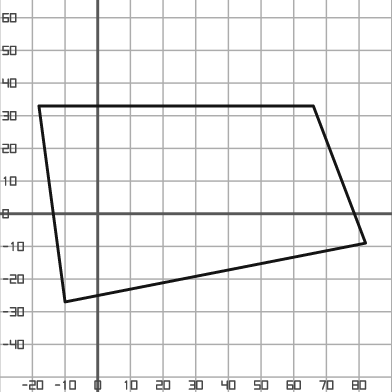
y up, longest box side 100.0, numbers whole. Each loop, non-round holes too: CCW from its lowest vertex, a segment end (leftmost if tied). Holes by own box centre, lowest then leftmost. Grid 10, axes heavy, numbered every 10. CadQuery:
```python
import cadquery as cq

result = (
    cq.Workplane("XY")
    .moveTo(-10.0, -27.0)
    .lineTo(82.0, -9.0)
    .lineTo(66.0, 33.0)
    .lineTo(-18.0, 33.0)
    .close()
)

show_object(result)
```